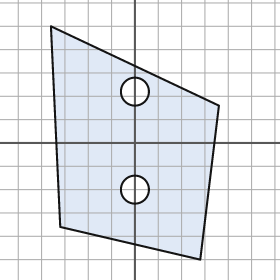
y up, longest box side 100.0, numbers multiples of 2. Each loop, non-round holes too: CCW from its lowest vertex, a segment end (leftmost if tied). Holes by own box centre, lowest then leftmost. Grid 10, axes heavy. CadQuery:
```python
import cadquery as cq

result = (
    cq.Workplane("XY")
    .moveTo(28.0, -50.0)
    .lineTo(36.0, 16.0)
    .lineTo(-36.0, 50.0)
    .lineTo(-32.0, -36.0)
    .close()
    .moveTo(0.0, -20.0)
    .circle(6.0)
    .moveTo(0.0, 22.0)
    .circle(6.0)
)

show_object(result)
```